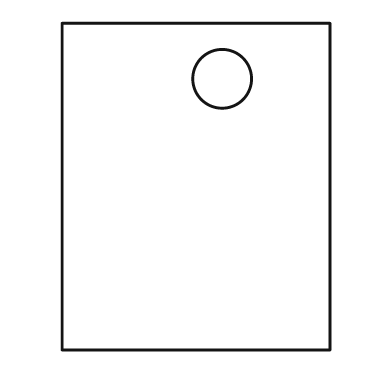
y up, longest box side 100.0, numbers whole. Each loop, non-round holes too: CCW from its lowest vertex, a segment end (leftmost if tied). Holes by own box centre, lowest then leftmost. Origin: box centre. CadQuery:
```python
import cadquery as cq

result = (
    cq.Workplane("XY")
    .moveTo(-41.0, -50.0)
    .lineTo(41.0, -50.0)
    .lineTo(41.0, 50.0)
    .lineTo(-41.0, 50.0)
    .close()
    .moveTo(8.0, 33.0)
    .circle(9.0)
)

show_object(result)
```